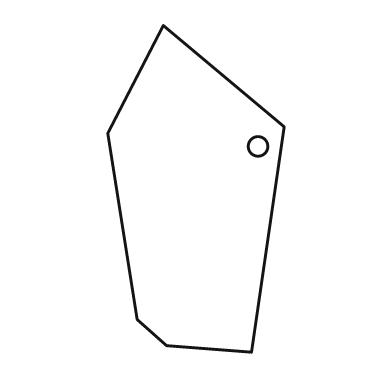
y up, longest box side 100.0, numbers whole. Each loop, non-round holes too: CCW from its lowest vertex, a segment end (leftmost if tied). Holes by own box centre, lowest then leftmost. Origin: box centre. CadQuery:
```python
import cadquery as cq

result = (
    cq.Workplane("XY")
    .moveTo(17.0, -50.0)
    .lineTo(27.0, 19.0)
    .lineTo(-10.0, 50.0)
    .lineTo(-27.0, 17.0)
    .lineTo(-18.0, -40.0)
    .lineTo(-9.0, -48.0)
    .close()
    .moveTo(19.0, 13.0)
    .circle(3.0)
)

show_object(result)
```